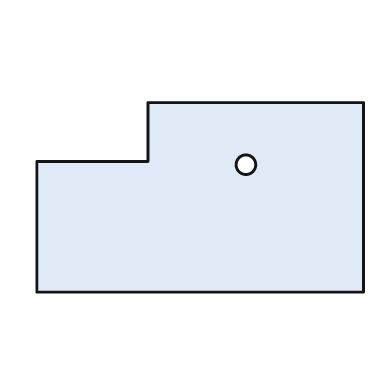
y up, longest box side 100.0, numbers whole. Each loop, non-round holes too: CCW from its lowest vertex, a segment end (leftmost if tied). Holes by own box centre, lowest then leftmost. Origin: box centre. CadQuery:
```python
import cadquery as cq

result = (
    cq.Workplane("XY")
    .moveTo(-50.0, -29.0)
    .lineTo(50.0, -29.0)
    .lineTo(50.0, 29.0)
    .lineTo(-16.0, 29.0)
    .lineTo(-16.0, 11.0)
    .lineTo(-50.0, 11.0)
    .close()
    .moveTo(14.0, 10.0)
    .circle(3.0)
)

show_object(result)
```